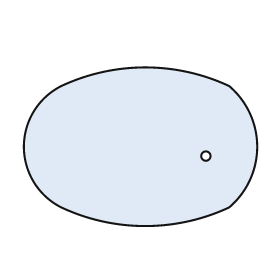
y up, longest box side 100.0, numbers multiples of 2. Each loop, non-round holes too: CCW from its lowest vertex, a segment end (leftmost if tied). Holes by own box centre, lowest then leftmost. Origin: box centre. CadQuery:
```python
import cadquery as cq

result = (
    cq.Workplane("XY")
    .moveTo(-34.0, -26.0)
    .threePointArc((2.0, -34.0), (38.0, -26.0))
    .threePointArc((50.0, 0.0), (38.0, 26.0))
    .threePointArc((2.0, 34.0), (-34.0, 26.0))
    .threePointArc((-50.0, 0.0), (-34.0, -26.0))
    .close()
    .moveTo(28.0, -4.0)
    .circle(2.0)
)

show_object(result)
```